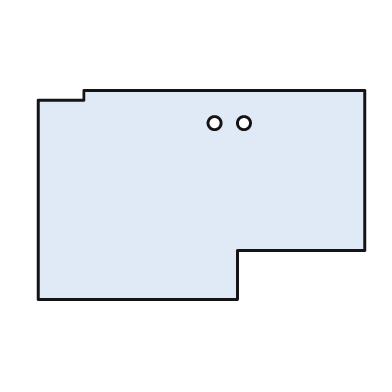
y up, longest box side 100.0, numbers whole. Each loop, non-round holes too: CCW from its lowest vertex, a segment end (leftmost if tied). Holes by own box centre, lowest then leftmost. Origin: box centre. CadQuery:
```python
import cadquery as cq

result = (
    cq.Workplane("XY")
    .moveTo(-50.0, -32.0)
    .lineTo(11.0, -32.0)
    .lineTo(11.0, -17.0)
    .lineTo(50.0, -17.0)
    .lineTo(50.0, 32.0)
    .lineTo(-36.0, 32.0)
    .lineTo(-36.0, 29.0)
    .lineTo(-50.0, 29.0)
    .close()
    .moveTo(4.0, 22.0)
    .circle(2.0)
    .moveTo(13.0, 22.0)
    .circle(2.0)
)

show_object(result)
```